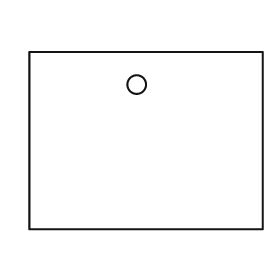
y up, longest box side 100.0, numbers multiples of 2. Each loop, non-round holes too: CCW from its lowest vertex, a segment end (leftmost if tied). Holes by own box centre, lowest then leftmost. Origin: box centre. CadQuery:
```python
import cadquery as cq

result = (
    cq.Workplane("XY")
    .moveTo(-50.0, -38.0)
    .lineTo(50.0, -38.0)
    .lineTo(50.0, 38.0)
    .lineTo(-50.0, 38.0)
    .close()
    .moveTo(-4.0, 24.0)
    .circle(4.0)
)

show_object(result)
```